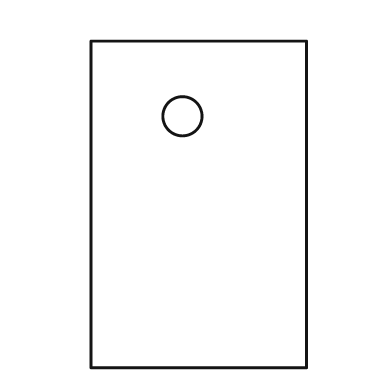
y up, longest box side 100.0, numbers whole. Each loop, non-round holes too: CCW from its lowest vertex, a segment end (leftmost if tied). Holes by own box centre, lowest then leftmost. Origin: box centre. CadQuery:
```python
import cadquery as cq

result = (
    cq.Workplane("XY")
    .moveTo(-33.0, -50.0)
    .lineTo(33.0, -50.0)
    .lineTo(33.0, 50.0)
    .lineTo(-33.0, 50.0)
    .close()
    .moveTo(-5.0, 27.0)
    .circle(6.0)
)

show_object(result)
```